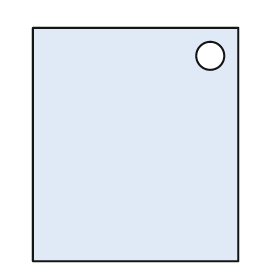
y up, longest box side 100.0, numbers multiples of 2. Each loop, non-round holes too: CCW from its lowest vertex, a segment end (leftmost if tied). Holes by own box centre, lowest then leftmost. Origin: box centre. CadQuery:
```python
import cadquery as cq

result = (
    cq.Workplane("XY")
    .moveTo(-44.0, -50.0)
    .lineTo(44.0, -50.0)
    .lineTo(44.0, 50.0)
    .lineTo(-44.0, 50.0)
    .close()
    .moveTo(32.0, 38.0)
    .circle(6.0)
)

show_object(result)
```